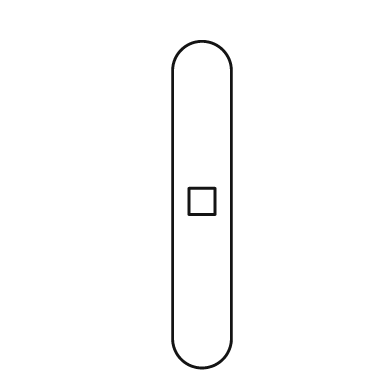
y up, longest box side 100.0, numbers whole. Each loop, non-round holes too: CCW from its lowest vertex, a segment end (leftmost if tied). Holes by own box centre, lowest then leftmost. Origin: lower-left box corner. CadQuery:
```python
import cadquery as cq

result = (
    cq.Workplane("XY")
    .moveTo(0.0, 9.0)
    .threePointArc((9.0, 0.0), (18.0, 9.0))
    .lineTo(18.0, 91.0)
    .threePointArc((9.0, 100.0), (0.0, 91.0))
    .close()
    .moveTo(5.0, 47.0)
    .lineTo(13.0, 47.0)
    .lineTo(13.0, 55.0)
    .lineTo(5.0, 55.0)
    .close()
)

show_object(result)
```